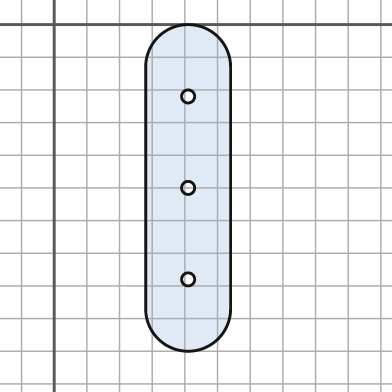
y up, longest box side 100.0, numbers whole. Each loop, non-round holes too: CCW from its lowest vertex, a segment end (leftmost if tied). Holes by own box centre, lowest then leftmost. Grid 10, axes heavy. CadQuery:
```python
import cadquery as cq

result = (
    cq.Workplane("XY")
    .moveTo(28.0, -87.0)
    .threePointArc((41.0, -100.0), (54.0, -87.0))
    .lineTo(54.0, -13.0)
    .threePointArc((41.0, 0.0), (28.0, -13.0))
    .close()
    .moveTo(41.0, -78.0)
    .circle(2.0)
    .moveTo(41.0, -50.0)
    .circle(2.0)
    .moveTo(41.0, -22.0)
    .circle(2.0)
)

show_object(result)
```